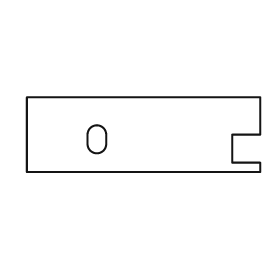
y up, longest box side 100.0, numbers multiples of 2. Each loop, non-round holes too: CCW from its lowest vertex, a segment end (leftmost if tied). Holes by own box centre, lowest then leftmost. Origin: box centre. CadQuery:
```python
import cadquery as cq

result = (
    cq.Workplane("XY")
    .moveTo(-50.0, -16.0)
    .lineTo(50.0, -16.0)
    .lineTo(50.0, -12.0)
    .lineTo(38.0, -12.0)
    .lineTo(38.0, 0.0)
    .lineTo(50.0, 0.0)
    .lineTo(50.0, 16.0)
    .lineTo(-50.0, 16.0)
    .close()
    .moveTo(-24.0, -4.0)
    .threePointArc((-20.0, -8.0), (-16.0, -4.0))
    .lineTo(-16.0, 0.0)
    .threePointArc((-20.0, 4.0), (-24.0, 0.0))
    .close()
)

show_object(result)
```